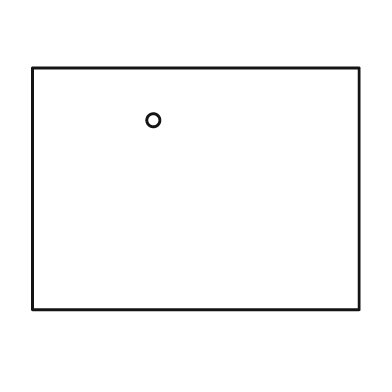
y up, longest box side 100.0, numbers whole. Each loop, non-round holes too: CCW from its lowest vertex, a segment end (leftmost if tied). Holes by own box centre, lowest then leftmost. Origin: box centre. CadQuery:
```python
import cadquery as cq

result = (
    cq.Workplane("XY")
    .moveTo(-50.0, -37.0)
    .lineTo(50.0, -37.0)
    .lineTo(50.0, 37.0)
    .lineTo(-50.0, 37.0)
    .close()
    .moveTo(-13.0, 21.0)
    .circle(2.0)
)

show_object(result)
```